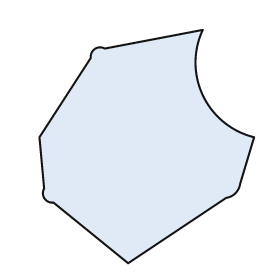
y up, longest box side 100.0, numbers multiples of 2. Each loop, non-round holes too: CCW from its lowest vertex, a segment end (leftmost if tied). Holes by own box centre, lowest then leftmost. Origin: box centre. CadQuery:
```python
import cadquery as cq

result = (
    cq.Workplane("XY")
    .moveTo(-8.0, -50.0)
    .lineTo(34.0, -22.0)
    .threePointArc((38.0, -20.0), (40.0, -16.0))
    .lineTo(46.0, 4.0)
    .threePointArc((24.0, 22.0), (24.0, 50.0))
    .lineTo(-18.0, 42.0)
    .threePointArc((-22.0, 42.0), (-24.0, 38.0))
    .lineTo(-46.0, 4.0)
    .lineTo(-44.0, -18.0)
    .threePointArc((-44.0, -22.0), (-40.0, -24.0))
    .close()
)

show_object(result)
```